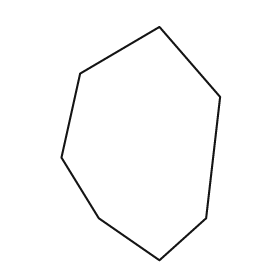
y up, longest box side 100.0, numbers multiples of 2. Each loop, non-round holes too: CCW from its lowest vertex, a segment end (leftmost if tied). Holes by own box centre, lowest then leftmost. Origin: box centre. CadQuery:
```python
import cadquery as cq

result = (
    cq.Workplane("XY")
    .moveTo(8.0, -50.0)
    .lineTo(28.0, -32.0)
    .lineTo(34.0, 20.0)
    .lineTo(8.0, 50.0)
    .lineTo(-26.0, 30.0)
    .lineTo(-34.0, -6.0)
    .lineTo(-18.0, -32.0)
    .close()
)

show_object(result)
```